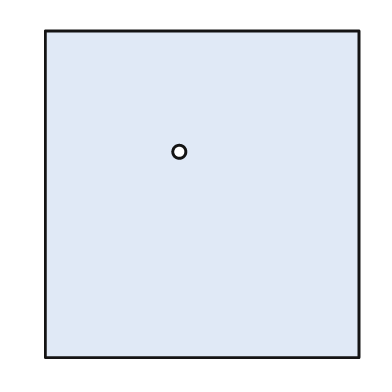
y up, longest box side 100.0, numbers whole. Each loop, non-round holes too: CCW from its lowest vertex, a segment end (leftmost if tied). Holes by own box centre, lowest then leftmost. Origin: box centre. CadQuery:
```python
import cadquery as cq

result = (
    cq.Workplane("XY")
    .moveTo(-48.0, -50.0)
    .lineTo(48.0, -50.0)
    .lineTo(48.0, 50.0)
    .lineTo(-48.0, 50.0)
    .close()
    .moveTo(-7.0, 13.0)
    .circle(2.0)
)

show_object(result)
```